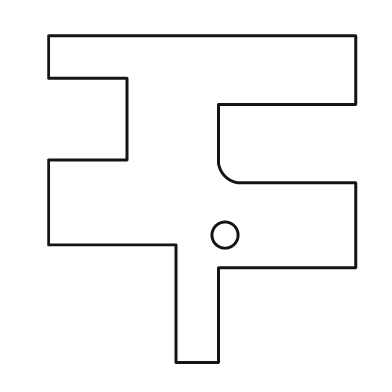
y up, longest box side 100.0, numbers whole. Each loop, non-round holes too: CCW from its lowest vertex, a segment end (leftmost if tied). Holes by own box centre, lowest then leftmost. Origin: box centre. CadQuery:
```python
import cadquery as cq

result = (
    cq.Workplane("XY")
    .moveTo(-8.0, -50.0)
    .lineTo(5.0, -50.0)
    .lineTo(5.0, -21.0)
    .lineTo(47.0, -21.0)
    .lineTo(47.0, 5.0)
    .lineTo(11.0, 5.0)
    .threePointArc((7.0, 7.0), (5.0, 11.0))
    .lineTo(5.0, 29.0)
    .lineTo(47.0, 29.0)
    .lineTo(47.0, 50.0)
    .lineTo(-47.0, 50.0)
    .lineTo(-47.0, 37.0)
    .lineTo(-23.0, 37.0)
    .lineTo(-23.0, 12.0)
    .lineTo(-47.0, 12.0)
    .lineTo(-47.0, -14.0)
    .lineTo(-8.0, -14.0)
    .close()
    .moveTo(7.0, -11.0)
    .circle(4.0)
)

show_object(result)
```